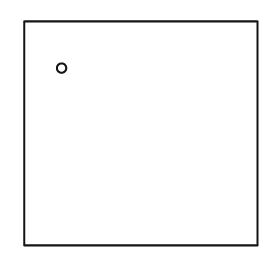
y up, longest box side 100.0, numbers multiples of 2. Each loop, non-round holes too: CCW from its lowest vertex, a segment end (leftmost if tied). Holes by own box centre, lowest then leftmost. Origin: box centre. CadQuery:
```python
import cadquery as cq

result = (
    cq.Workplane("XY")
    .moveTo(-50.0, -48.0)
    .lineTo(50.0, -48.0)
    .lineTo(50.0, 48.0)
    .lineTo(-50.0, 48.0)
    .close()
    .moveTo(-34.0, 28.0)
    .circle(2.0)
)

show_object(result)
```